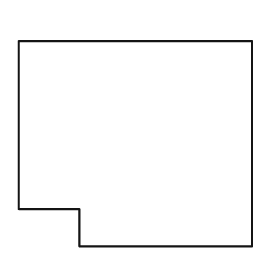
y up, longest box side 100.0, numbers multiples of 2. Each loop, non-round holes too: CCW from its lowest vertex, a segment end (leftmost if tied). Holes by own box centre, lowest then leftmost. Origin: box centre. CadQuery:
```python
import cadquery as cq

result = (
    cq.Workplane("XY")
    .moveTo(-24.0, -44.0)
    .lineTo(50.0, -44.0)
    .lineTo(50.0, 44.0)
    .lineTo(-50.0, 44.0)
    .lineTo(-50.0, -28.0)
    .lineTo(-24.0, -28.0)
    .close()
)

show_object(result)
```